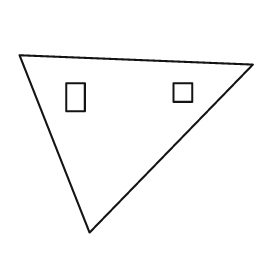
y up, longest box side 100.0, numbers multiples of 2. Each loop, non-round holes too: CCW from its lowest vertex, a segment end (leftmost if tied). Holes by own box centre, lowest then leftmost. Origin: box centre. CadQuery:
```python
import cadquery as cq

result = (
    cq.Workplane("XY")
    .moveTo(-20.0, -38.0)
    .lineTo(50.0, 34.0)
    .lineTo(-50.0, 38.0)
    .close()
    .moveTo(-30.0, 14.0)
    .lineTo(-22.0, 14.0)
    .lineTo(-22.0, 26.0)
    .lineTo(-30.0, 26.0)
    .close()
    .moveTo(16.0, 18.0)
    .lineTo(24.0, 18.0)
    .lineTo(24.0, 26.0)
    .lineTo(16.0, 26.0)
    .close()
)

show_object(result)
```